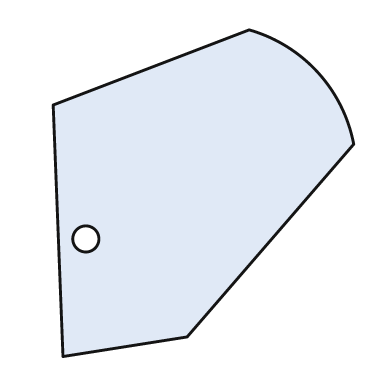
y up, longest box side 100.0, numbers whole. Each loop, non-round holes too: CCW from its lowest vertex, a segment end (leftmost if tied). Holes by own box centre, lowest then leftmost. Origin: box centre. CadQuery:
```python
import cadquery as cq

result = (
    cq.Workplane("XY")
    .moveTo(-43.0, -50.0)
    .lineTo(-5.0, -44.0)
    .lineTo(46.0, 15.0)
    .threePointArc((35.0, 37.0), (14.0, 50.0))
    .lineTo(-46.0, 27.0)
    .close()
    .moveTo(-36.0, -14.0)
    .circle(4.0)
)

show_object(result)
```